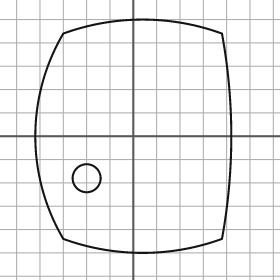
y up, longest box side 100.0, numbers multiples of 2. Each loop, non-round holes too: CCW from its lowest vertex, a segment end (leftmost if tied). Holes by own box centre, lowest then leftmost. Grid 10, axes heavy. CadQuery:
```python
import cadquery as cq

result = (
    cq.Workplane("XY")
    .moveTo(-30.0, -44.0)
    .threePointArc((4.0, -50.0), (38.0, -44.0))
    .threePointArc((42.0, 0.0), (38.0, 44.0))
    .threePointArc((4.0, 50.0), (-30.0, 44.0))
    .threePointArc((-42.0, 0.0), (-30.0, -44.0))
    .close()
    .moveTo(-20.0, -18.0)
    .circle(6.0)
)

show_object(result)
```